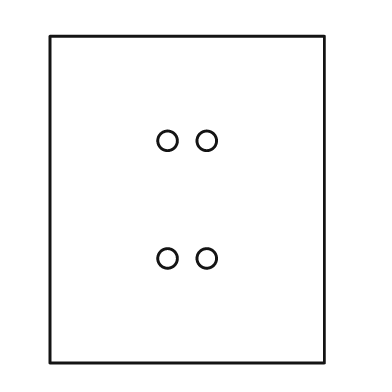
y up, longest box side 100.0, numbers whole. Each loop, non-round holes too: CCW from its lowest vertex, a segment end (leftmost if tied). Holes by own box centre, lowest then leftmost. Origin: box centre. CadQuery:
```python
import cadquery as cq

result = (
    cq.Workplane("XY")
    .moveTo(-42.0, -50.0)
    .lineTo(42.0, -50.0)
    .lineTo(42.0, 50.0)
    .lineTo(-42.0, 50.0)
    .close()
    .moveTo(-6.0, -18.0)
    .circle(3.0)
    .moveTo(6.0, -18.0)
    .circle(3.0)
    .moveTo(-6.0, 18.0)
    .circle(3.0)
    .moveTo(6.0, 18.0)
    .circle(3.0)
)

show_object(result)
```